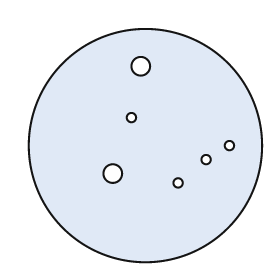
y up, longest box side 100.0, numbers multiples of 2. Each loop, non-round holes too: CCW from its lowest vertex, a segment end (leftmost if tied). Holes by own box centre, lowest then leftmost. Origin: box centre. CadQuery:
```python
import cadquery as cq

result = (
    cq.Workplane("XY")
    .moveTo(0.0, 0.0)
    .circle(50.0)
    .moveTo(14.0, -16.0)
    .circle(2.0)
    .moveTo(-14.0, -12.0)
    .circle(4.0)
    .moveTo(26.0, -6.0)
    .circle(2.0)
    .moveTo(36.0, 0.0)
    .circle(2.0)
    .moveTo(-6.0, 12.0)
    .circle(2.0)
    .moveTo(-2.0, 34.0)
    .circle(4.0)
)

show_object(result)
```